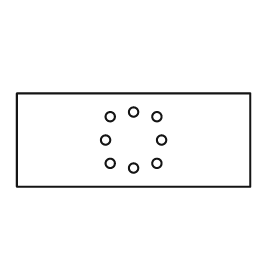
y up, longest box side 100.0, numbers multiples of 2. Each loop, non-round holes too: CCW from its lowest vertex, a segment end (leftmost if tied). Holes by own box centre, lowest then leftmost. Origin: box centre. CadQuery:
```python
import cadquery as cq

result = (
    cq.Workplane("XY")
    .moveTo(-50.0, -20.0)
    .lineTo(50.0, -20.0)
    .lineTo(50.0, 20.0)
    .lineTo(-50.0, 20.0)
    .close()
    .moveTo(0.0, -12.0)
    .circle(2.0)
    .moveTo(-10.0, -10.0)
    .circle(2.0)
    .moveTo(10.0, -10.0)
    .circle(2.0)
    .moveTo(-12.0, 0.0)
    .circle(2.0)
    .moveTo(12.0, 0.0)
    .circle(2.0)
    .moveTo(-10.0, 10.0)
    .circle(2.0)
    .moveTo(10.0, 10.0)
    .circle(2.0)
    .moveTo(0.0, 12.0)
    .circle(2.0)
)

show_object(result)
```